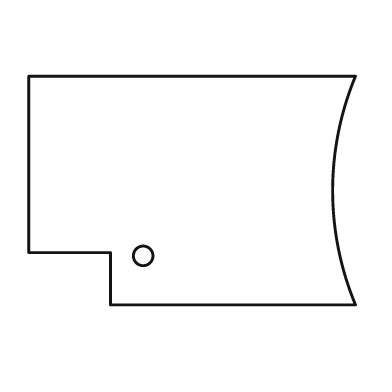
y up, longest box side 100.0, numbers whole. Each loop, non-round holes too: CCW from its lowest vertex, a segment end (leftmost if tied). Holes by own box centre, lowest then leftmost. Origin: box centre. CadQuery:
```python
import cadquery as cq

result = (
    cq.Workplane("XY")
    .moveTo(-25.0, -35.0)
    .lineTo(50.0, -35.0)
    .threePointArc((43.0, 0.0), (50.0, 35.0))
    .lineTo(-50.0, 35.0)
    .lineTo(-50.0, -19.0)
    .lineTo(-25.0, -19.0)
    .close()
    .moveTo(-15.0, -20.0)
    .circle(3.0)
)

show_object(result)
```